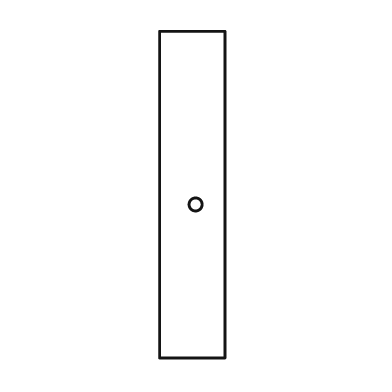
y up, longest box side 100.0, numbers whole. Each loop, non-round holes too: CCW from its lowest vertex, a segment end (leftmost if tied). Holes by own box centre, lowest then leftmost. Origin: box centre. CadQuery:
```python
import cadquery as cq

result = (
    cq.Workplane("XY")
    .moveTo(-10.0, -50.0)
    .lineTo(10.0, -50.0)
    .lineTo(10.0, 50.0)
    .lineTo(-10.0, 50.0)
    .close()
    .moveTo(1.0, -3.0)
    .circle(2.0)
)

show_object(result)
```